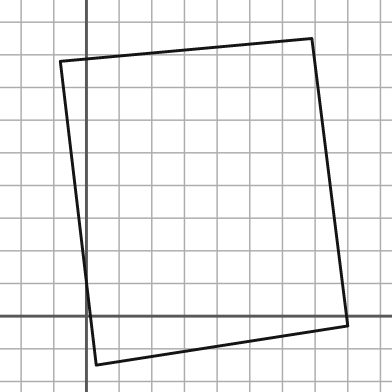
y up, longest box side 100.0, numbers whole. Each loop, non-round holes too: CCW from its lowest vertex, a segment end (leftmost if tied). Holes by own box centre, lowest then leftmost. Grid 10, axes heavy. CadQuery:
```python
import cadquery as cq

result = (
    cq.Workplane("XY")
    .moveTo(3.0, -15.0)
    .lineTo(80.0, -3.0)
    .lineTo(69.0, 85.0)
    .lineTo(-8.0, 78.0)
    .close()
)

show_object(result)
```